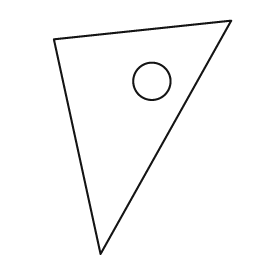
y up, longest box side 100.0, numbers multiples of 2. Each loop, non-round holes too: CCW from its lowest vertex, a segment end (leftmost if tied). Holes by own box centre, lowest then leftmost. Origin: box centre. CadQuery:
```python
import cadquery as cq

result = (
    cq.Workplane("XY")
    .moveTo(-18.0, -50.0)
    .lineTo(38.0, 50.0)
    .lineTo(-38.0, 42.0)
    .close()
    .moveTo(4.0, 24.0)
    .circle(8.0)
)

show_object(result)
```